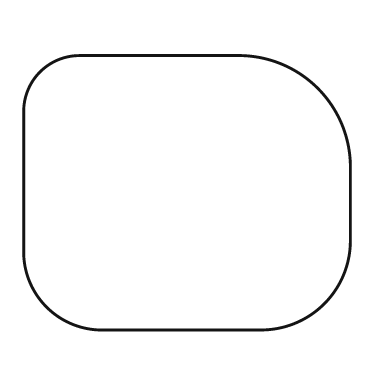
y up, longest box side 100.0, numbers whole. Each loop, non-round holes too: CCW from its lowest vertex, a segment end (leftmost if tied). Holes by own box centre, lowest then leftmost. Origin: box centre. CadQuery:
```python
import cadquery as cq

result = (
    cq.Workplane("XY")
    .moveTo(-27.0, -42.0)
    .lineTo(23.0, -42.0)
    .threePointArc((42.0, -34.0), (50.0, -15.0))
    .lineTo(50.0, 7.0)
    .threePointArc((40.0, 32.0), (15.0, 42.0))
    .lineTo(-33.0, 42.0)
    .threePointArc((-45.0, 37.0), (-50.0, 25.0))
    .lineTo(-50.0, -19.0)
    .threePointArc((-43.0, -35.0), (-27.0, -42.0))
    .close()
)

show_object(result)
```